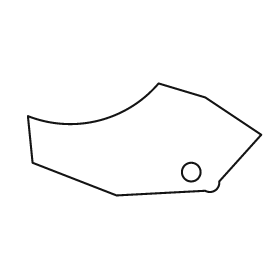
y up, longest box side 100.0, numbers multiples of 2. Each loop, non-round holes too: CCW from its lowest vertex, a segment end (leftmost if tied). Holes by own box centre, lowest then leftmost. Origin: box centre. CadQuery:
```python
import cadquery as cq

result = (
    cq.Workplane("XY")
    .moveTo(-12.0, -24.0)
    .lineTo(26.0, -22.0)
    .threePointArc((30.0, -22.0), (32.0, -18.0))
    .lineTo(50.0, 2.0)
    .lineTo(26.0, 18.0)
    .lineTo(6.0, 24.0)
    .threePointArc((-20.0, 8.0), (-50.0, 10.0))
    .lineTo(-48.0, -10.0)
    .close()
    .moveTo(20.0, -14.0)
    .circle(4.0)
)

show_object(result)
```